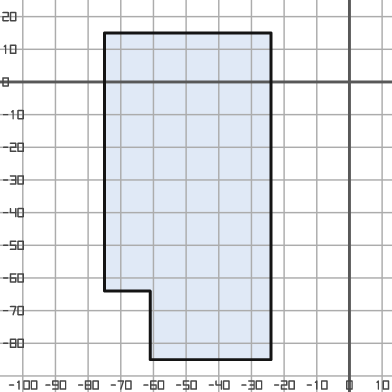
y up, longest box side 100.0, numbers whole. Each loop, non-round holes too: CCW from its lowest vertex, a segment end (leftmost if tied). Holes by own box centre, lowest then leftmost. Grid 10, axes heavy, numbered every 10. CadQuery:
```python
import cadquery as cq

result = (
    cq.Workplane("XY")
    .moveTo(-61.0, -85.0)
    .lineTo(-24.0, -85.0)
    .lineTo(-24.0, 15.0)
    .lineTo(-75.0, 15.0)
    .lineTo(-75.0, -64.0)
    .lineTo(-61.0, -64.0)
    .close()
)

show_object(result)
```